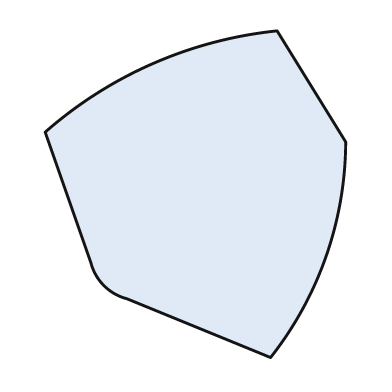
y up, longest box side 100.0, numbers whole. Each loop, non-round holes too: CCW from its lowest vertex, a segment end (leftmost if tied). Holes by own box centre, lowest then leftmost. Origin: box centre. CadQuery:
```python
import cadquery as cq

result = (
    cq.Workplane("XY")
    .moveTo(23.0, -50.0)
    .threePointArc((40.0, -19.0), (46.0, 16.0))
    .lineTo(25.0, 50.0)
    .threePointArc((-13.0, 40.0), (-46.0, 19.0))
    .lineTo(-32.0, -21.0)
    .threePointArc((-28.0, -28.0), (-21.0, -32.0))
    .close()
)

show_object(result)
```